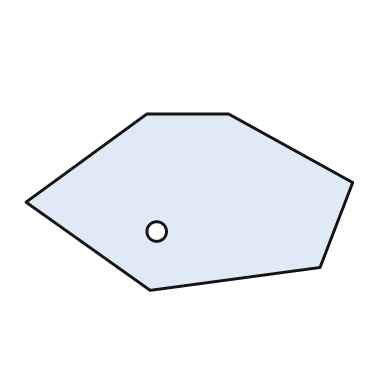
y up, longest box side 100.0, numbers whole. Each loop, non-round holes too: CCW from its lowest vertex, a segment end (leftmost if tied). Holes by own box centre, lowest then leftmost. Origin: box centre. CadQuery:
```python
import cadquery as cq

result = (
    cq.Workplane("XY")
    .moveTo(-12.0, -27.0)
    .lineTo(40.0, -20.0)
    .lineTo(50.0, 6.0)
    .lineTo(12.0, 27.0)
    .lineTo(-13.0, 27.0)
    .lineTo(-50.0, 0.0)
    .close()
    .moveTo(-10.0, -9.0)
    .circle(3.0)
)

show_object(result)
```